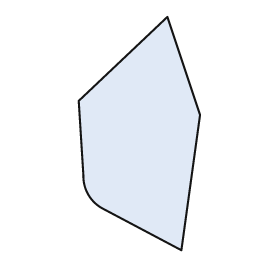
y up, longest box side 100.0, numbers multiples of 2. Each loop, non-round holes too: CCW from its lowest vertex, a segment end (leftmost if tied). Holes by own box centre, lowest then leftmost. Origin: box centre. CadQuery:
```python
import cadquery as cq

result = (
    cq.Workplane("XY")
    .moveTo(18.0, -50.0)
    .lineTo(26.0, 8.0)
    .lineTo(12.0, 50.0)
    .lineTo(-26.0, 14.0)
    .lineTo(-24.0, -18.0)
    .threePointArc((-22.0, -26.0), (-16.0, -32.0))
    .close()
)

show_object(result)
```